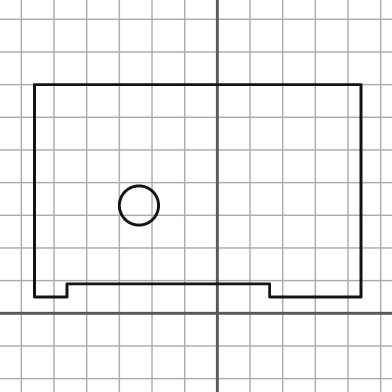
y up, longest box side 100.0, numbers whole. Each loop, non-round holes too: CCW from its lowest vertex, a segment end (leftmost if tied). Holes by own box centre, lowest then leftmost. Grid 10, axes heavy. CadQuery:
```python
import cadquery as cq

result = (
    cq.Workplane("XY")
    .moveTo(-56.0, 5.0)
    .lineTo(-46.0, 5.0)
    .lineTo(-46.0, 9.0)
    .lineTo(16.0, 9.0)
    .lineTo(16.0, 5.0)
    .lineTo(44.0, 5.0)
    .lineTo(44.0, 70.0)
    .lineTo(-56.0, 70.0)
    .close()
    .moveTo(-24.0, 33.0)
    .circle(6.0)
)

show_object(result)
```